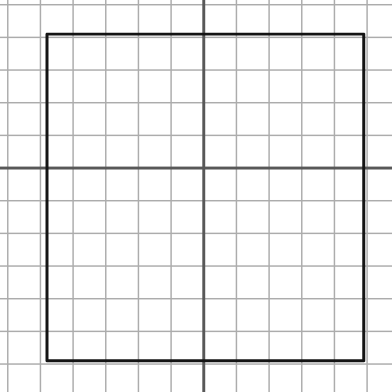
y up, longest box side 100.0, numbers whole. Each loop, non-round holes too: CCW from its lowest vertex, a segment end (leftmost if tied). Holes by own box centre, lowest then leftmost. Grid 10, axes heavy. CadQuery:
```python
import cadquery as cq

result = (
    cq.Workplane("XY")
    .moveTo(-48.0, -59.0)
    .lineTo(49.0, -59.0)
    .lineTo(49.0, 41.0)
    .lineTo(-48.0, 41.0)
    .close()
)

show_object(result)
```